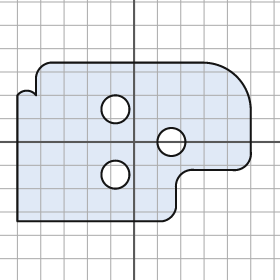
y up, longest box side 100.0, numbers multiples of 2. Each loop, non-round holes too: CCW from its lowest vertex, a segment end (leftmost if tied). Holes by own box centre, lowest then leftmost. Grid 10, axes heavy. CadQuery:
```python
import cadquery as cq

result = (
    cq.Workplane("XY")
    .moveTo(-50.0, -34.0)
    .lineTo(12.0, -34.0)
    .threePointArc((16.0, -32.0), (18.0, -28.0))
    .lineTo(18.0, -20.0)
    .threePointArc((20.0, -14.0), (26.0, -12.0))
    .lineTo(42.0, -12.0)
    .threePointArc((48.0, -10.0), (50.0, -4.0))
    .lineTo(50.0, 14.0)
    .threePointArc((44.0, 28.0), (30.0, 34.0))
    .lineTo(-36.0, 34.0)
    .threePointArc((-40.0, 32.0), (-42.0, 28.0))
    .lineTo(-42.0, 20.0)
    .threePointArc((-46.0, 22.0), (-50.0, 20.0))
    .close()
    .moveTo(-8.0, -14.0)
    .circle(6.0)
    .moveTo(16.0, 0.0)
    .circle(6.0)
    .moveTo(-8.0, 14.0)
    .circle(6.0)
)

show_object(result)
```